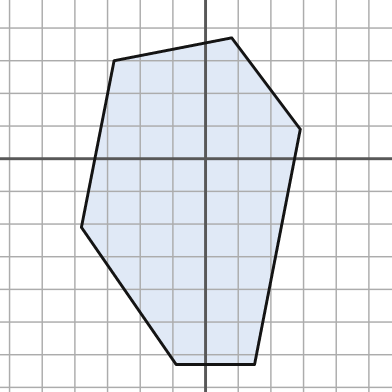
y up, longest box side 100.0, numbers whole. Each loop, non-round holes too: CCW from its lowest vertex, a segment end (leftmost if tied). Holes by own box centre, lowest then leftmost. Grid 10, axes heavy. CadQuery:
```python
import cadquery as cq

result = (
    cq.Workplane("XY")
    .moveTo(-9.0, -63.0)
    .lineTo(15.0, -63.0)
    .lineTo(29.0, 9.0)
    .lineTo(8.0, 37.0)
    .lineTo(-28.0, 30.0)
    .lineTo(-38.0, -21.0)
    .close()
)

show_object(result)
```